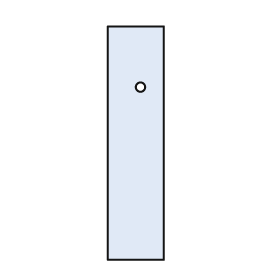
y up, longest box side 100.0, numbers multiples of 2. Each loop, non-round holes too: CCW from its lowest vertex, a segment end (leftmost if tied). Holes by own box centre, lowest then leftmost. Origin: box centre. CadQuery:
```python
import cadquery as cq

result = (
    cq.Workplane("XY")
    .moveTo(-12.0, -50.0)
    .lineTo(12.0, -50.0)
    .lineTo(12.0, 50.0)
    .lineTo(-12.0, 50.0)
    .close()
    .moveTo(2.0, 24.0)
    .circle(2.0)
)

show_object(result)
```